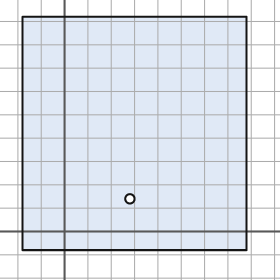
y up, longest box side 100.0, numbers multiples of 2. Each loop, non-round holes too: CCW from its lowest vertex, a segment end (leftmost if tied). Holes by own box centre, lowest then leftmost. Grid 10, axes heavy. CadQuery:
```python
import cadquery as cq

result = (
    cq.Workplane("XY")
    .moveTo(-18.0, -8.0)
    .lineTo(78.0, -8.0)
    .lineTo(78.0, 92.0)
    .lineTo(-18.0, 92.0)
    .close()
    .moveTo(28.0, 14.0)
    .circle(2.0)
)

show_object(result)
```